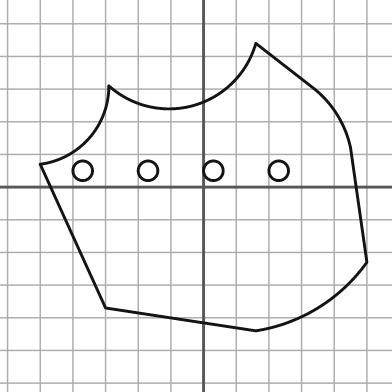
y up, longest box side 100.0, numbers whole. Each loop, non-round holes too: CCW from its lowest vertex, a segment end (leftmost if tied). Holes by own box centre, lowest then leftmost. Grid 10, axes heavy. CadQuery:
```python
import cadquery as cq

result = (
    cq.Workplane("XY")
    .moveTo(16.0, -44.0)
    .threePointArc((35.0, -37.0), (50.0, -23.0))
    .lineTo(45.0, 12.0)
    .threePointArc((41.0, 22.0), (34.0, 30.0))
    .lineTo(16.0, 44.0)
    .threePointArc((-3.0, 25.0), (-29.0, 31.0))
    .threePointArc((-35.0, 15.0), (-50.0, 7.0))
    .lineTo(-30.0, -37.0)
    .close()
    .moveTo(-37.0, 5.0)
    .circle(3.0)
    .moveTo(-17.0, 5.0)
    .circle(3.0)
    .moveTo(3.0, 5.0)
    .circle(3.0)
    .moveTo(23.0, 5.0)
    .circle(3.0)
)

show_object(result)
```